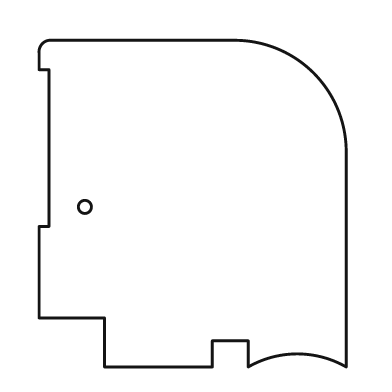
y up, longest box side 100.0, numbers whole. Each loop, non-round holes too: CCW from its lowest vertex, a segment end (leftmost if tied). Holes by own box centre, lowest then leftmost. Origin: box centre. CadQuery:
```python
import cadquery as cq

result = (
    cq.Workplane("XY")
    .moveTo(-27.0, -50.0)
    .lineTo(6.0, -50.0)
    .lineTo(6.0, -42.0)
    .lineTo(17.0, -42.0)
    .lineTo(17.0, -50.0)
    .threePointArc((32.0, -46.0), (47.0, -50.0))
    .lineTo(47.0, 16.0)
    .threePointArc((37.0, 40.0), (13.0, 50.0))
    .lineTo(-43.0, 50.0)
    .threePointArc((-46.0, 49.0), (-47.0, 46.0))
    .lineTo(-47.0, 41.0)
    .lineTo(-44.0, 41.0)
    .lineTo(-44.0, -7.0)
    .lineTo(-47.0, -7.0)
    .lineTo(-47.0, -35.0)
    .lineTo(-27.0, -35.0)
    .close()
    .moveTo(-33.0, -1.0)
    .circle(2.0)
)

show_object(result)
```